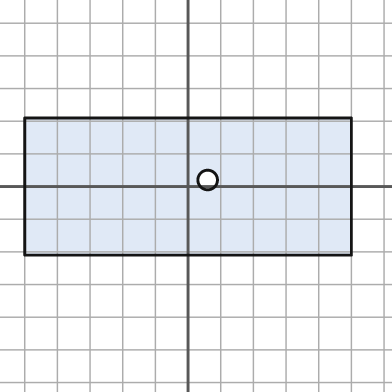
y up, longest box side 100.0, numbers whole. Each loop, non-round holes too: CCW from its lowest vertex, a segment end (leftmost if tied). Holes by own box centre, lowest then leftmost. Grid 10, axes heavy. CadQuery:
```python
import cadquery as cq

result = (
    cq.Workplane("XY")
    .moveTo(-50.0, -21.0)
    .lineTo(50.0, -21.0)
    .lineTo(50.0, 21.0)
    .lineTo(-50.0, 21.0)
    .close()
    .moveTo(6.0, 2.0)
    .circle(3.0)
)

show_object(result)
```